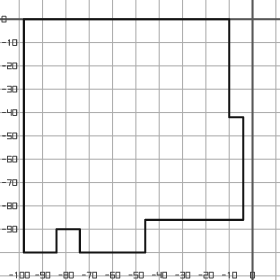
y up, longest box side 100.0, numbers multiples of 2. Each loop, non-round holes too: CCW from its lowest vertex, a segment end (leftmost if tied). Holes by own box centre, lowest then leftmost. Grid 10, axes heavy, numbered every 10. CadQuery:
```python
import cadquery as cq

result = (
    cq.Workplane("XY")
    .moveTo(-98.0, -100.0)
    .lineTo(-84.0, -100.0)
    .lineTo(-84.0, -90.0)
    .lineTo(-74.0, -90.0)
    .lineTo(-74.0, -100.0)
    .lineTo(-46.0, -100.0)
    .lineTo(-46.0, -86.0)
    .lineTo(-4.0, -86.0)
    .lineTo(-4.0, -42.0)
    .lineTo(-10.0, -42.0)
    .lineTo(-10.0, 0.0)
    .lineTo(-98.0, 0.0)
    .close()
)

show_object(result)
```